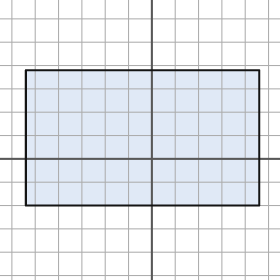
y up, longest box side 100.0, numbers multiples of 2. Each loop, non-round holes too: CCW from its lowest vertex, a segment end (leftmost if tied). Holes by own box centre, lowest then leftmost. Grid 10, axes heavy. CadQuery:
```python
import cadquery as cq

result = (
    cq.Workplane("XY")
    .moveTo(-54.0, -20.0)
    .lineTo(46.0, -20.0)
    .lineTo(46.0, 38.0)
    .lineTo(-54.0, 38.0)
    .close()
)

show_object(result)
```